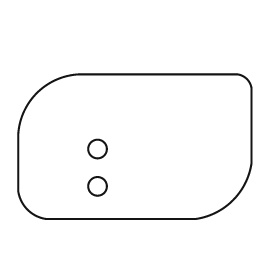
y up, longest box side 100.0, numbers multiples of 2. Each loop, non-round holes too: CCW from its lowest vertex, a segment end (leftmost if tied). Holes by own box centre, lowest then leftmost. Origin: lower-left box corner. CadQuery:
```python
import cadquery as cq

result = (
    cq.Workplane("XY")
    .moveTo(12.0, 0.0)
    .lineTo(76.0, 0.0)
    .threePointArc((92.0, 8.0), (100.0, 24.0))
    .lineTo(100.0, 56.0)
    .threePointArc((98.0, 60.0), (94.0, 62.0))
    .lineTo(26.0, 62.0)
    .threePointArc((8.0, 54.0), (0.0, 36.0))
    .lineTo(0.0, 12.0)
    .threePointArc((4.0, 4.0), (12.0, 0.0))
    .close()
    .moveTo(34.0, 14.0)
    .circle(4.0)
    .moveTo(34.0, 30.0)
    .circle(4.0)
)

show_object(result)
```